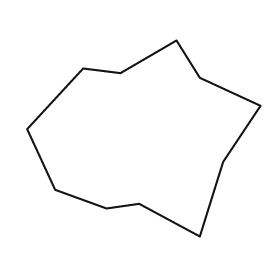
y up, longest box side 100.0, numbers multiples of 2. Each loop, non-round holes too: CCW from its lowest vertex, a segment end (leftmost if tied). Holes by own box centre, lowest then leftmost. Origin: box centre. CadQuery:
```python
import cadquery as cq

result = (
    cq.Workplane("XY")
    .moveTo(24.0, -42.0)
    .lineTo(34.0, -10.0)
    .lineTo(50.0, 14.0)
    .lineTo(24.0, 26.0)
    .lineTo(14.0, 42.0)
    .lineTo(-10.0, 28.0)
    .lineTo(-26.0, 30.0)
    .lineTo(-50.0, 4.0)
    .lineTo(-38.0, -22.0)
    .lineTo(-16.0, -30.0)
    .lineTo(-2.0, -28.0)
    .close()
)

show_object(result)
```